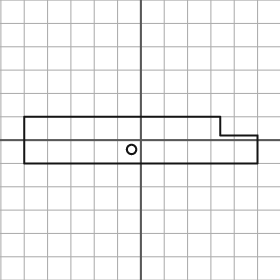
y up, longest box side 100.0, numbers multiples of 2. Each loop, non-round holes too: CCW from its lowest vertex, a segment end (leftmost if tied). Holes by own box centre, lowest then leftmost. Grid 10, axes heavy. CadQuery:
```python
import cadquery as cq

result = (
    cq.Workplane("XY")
    .moveTo(-50.0, -10.0)
    .lineTo(50.0, -10.0)
    .lineTo(50.0, 2.0)
    .lineTo(34.0, 2.0)
    .lineTo(34.0, 10.0)
    .lineTo(-50.0, 10.0)
    .close()
    .moveTo(-4.0, -4.0)
    .circle(2.0)
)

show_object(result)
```